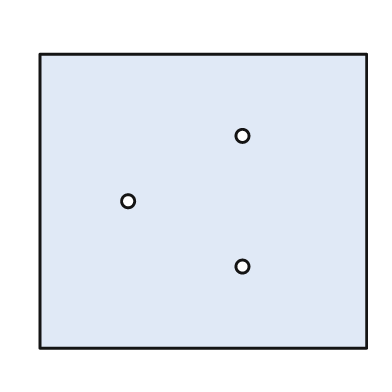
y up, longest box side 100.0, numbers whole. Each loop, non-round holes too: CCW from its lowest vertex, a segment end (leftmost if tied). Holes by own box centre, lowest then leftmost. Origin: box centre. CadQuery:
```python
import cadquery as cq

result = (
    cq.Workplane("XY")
    .moveTo(-50.0, -45.0)
    .lineTo(50.0, -45.0)
    .lineTo(50.0, 45.0)
    .lineTo(-50.0, 45.0)
    .close()
    .moveTo(12.0, -20.0)
    .circle(2.0)
    .moveTo(-23.0, 0.0)
    .circle(2.0)
    .moveTo(12.0, 20.0)
    .circle(2.0)
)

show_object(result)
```